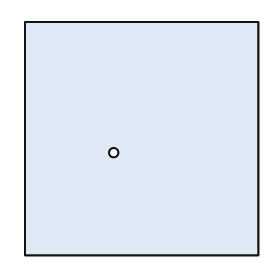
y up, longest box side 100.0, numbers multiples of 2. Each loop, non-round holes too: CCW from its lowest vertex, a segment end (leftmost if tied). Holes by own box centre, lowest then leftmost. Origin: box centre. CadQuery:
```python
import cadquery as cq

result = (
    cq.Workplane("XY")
    .moveTo(-50.0, -50.0)
    .lineTo(50.0, -50.0)
    .lineTo(50.0, 50.0)
    .lineTo(-50.0, 50.0)
    .close()
    .moveTo(-12.0, -6.0)
    .circle(2.0)
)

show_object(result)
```